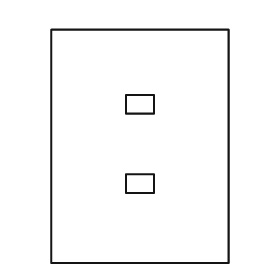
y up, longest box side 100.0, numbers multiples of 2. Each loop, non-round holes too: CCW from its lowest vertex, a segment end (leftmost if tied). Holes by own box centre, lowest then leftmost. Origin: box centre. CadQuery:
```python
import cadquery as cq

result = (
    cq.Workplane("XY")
    .moveTo(-38.0, -50.0)
    .lineTo(38.0, -50.0)
    .lineTo(38.0, 50.0)
    .lineTo(-38.0, 50.0)
    .close()
    .moveTo(-6.0, -20.0)
    .lineTo(6.0, -20.0)
    .lineTo(6.0, -12.0)
    .lineTo(-6.0, -12.0)
    .close()
    .moveTo(-6.0, 14.0)
    .lineTo(6.0, 14.0)
    .lineTo(6.0, 22.0)
    .lineTo(-6.0, 22.0)
    .close()
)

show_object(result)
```